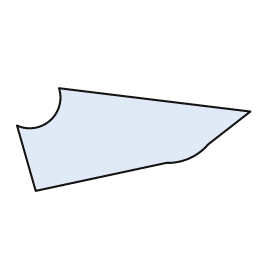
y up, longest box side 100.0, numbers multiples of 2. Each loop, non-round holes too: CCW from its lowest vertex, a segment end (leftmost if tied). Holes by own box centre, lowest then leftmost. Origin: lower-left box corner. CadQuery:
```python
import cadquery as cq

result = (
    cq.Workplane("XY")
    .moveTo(8.0, 0.0)
    .lineTo(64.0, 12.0)
    .threePointArc((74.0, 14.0), (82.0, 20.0))
    .lineTo(100.0, 34.0)
    .lineTo(18.0, 44.0)
    .threePointArc((14.0, 30.0), (0.0, 28.0))
    .close()
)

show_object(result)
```